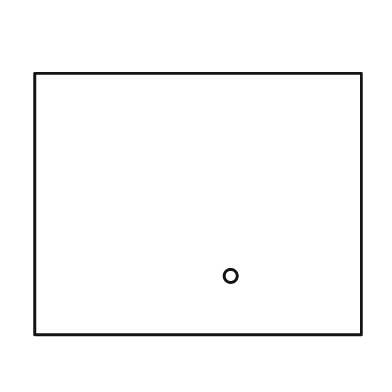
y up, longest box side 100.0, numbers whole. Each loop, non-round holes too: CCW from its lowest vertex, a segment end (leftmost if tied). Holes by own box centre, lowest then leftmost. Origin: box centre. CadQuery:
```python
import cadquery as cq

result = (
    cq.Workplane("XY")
    .moveTo(-50.0, -40.0)
    .lineTo(50.0, -40.0)
    .lineTo(50.0, 40.0)
    .lineTo(-50.0, 40.0)
    .close()
    .moveTo(10.0, -22.0)
    .circle(2.0)
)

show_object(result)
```